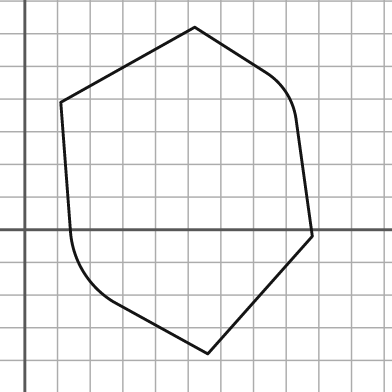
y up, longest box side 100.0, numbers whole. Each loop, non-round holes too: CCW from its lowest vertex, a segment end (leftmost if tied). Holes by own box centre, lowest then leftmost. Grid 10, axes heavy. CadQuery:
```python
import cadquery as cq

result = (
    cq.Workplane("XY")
    .moveTo(56.0, -38.0)
    .lineTo(88.0, -2.0)
    .lineTo(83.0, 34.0)
    .threePointArc((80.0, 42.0), (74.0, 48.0))
    .lineTo(52.0, 62.0)
    .lineTo(11.0, 39.0)
    .lineTo(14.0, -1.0)
    .threePointArc((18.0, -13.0), (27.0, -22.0))
    .close()
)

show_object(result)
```